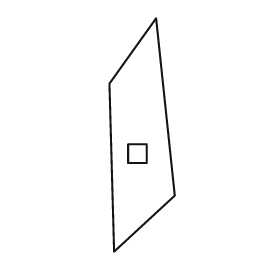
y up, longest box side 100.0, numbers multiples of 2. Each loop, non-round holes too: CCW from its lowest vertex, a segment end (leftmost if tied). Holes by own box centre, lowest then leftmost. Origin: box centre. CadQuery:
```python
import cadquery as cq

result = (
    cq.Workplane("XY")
    .moveTo(-12.0, -50.0)
    .lineTo(14.0, -26.0)
    .lineTo(6.0, 50.0)
    .lineTo(-14.0, 22.0)
    .close()
    .moveTo(-6.0, -12.0)
    .lineTo(2.0, -12.0)
    .lineTo(2.0, -4.0)
    .lineTo(-6.0, -4.0)
    .close()
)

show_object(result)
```